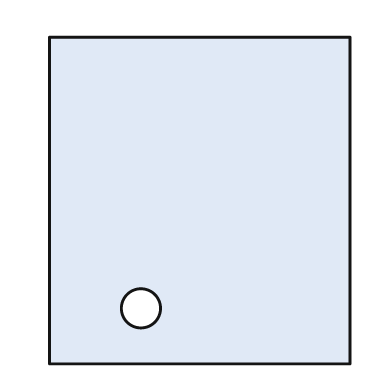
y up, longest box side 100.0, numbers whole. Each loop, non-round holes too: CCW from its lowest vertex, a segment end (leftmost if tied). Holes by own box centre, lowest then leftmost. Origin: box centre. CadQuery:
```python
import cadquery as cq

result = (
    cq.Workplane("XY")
    .moveTo(-46.0, -50.0)
    .lineTo(46.0, -50.0)
    .lineTo(46.0, 50.0)
    .lineTo(-46.0, 50.0)
    .close()
    .moveTo(-18.0, -33.0)
    .circle(6.0)
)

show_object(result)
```